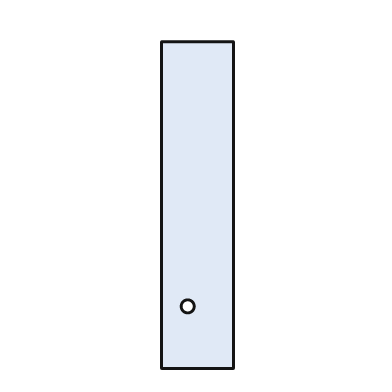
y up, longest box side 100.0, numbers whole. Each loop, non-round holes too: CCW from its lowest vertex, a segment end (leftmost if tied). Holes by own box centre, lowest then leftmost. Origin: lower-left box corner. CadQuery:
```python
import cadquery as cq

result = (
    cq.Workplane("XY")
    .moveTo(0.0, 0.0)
    .lineTo(22.0, 0.0)
    .lineTo(22.0, 100.0)
    .lineTo(0.0, 100.0)
    .close()
    .moveTo(8.0, 19.0)
    .circle(2.0)
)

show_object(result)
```